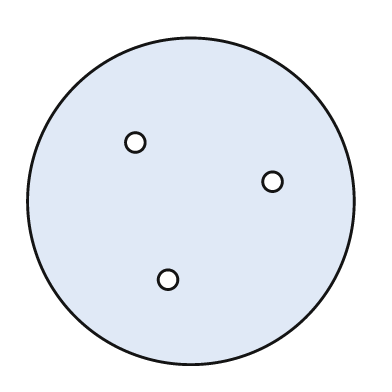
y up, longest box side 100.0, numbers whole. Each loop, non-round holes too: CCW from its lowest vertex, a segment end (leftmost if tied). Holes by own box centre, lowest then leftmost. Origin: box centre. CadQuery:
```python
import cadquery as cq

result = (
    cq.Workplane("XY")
    .moveTo(0.0, 0.0)
    .circle(50.0)
    .moveTo(-7.0, -24.0)
    .circle(3.0)
    .moveTo(25.0, 6.0)
    .circle(3.0)
    .moveTo(-17.0, 18.0)
    .circle(3.0)
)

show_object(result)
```